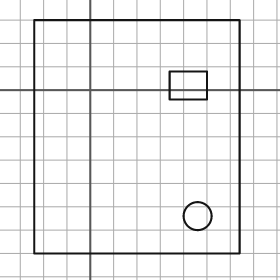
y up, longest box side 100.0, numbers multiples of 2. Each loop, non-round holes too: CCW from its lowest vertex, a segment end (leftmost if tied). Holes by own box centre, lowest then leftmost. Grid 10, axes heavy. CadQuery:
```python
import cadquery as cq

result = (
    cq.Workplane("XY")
    .moveTo(-24.0, -70.0)
    .lineTo(64.0, -70.0)
    .lineTo(64.0, 30.0)
    .lineTo(-24.0, 30.0)
    .close()
    .moveTo(46.0, -54.0)
    .circle(6.0)
    .moveTo(34.0, -4.0)
    .lineTo(50.0, -4.0)
    .lineTo(50.0, 8.0)
    .lineTo(34.0, 8.0)
    .close()
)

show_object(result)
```